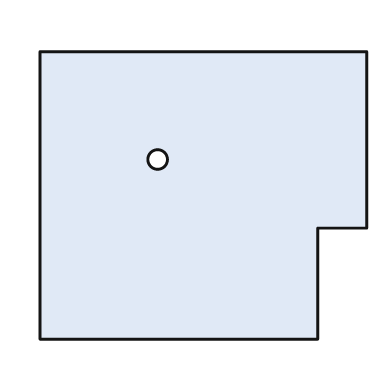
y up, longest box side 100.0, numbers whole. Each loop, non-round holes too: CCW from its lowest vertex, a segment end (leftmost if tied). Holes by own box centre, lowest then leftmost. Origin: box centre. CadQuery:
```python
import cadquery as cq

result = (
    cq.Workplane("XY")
    .moveTo(-50.0, -44.0)
    .lineTo(35.0, -44.0)
    .lineTo(35.0, -10.0)
    .lineTo(50.0, -10.0)
    .lineTo(50.0, 44.0)
    .lineTo(-50.0, 44.0)
    .close()
    .moveTo(-14.0, 11.0)
    .circle(3.0)
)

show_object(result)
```